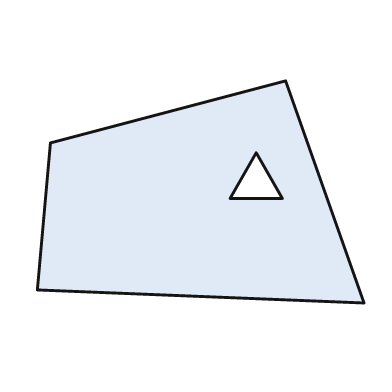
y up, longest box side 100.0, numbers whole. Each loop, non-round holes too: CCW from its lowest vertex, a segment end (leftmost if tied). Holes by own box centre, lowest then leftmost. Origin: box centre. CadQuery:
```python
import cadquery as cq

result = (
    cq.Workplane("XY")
    .moveTo(50.0, -34.0)
    .lineTo(26.0, 34.0)
    .lineTo(-46.0, 15.0)
    .lineTo(-50.0, -30.0)
    .close()
    .moveTo(9.0, -2.0)
    .lineTo(25.0, -2.0)
    .lineTo(17.0, 12.0)
    .close()
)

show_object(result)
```